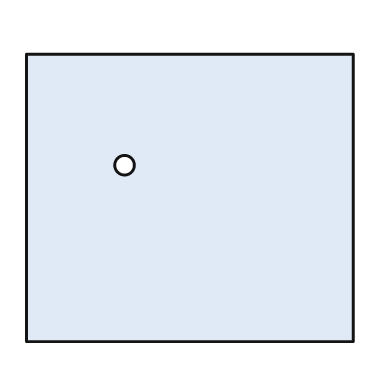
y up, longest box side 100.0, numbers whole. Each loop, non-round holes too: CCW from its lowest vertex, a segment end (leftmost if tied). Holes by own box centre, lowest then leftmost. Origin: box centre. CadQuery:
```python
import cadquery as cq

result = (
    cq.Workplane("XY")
    .moveTo(-50.0, -44.0)
    .lineTo(50.0, -44.0)
    .lineTo(50.0, 44.0)
    .lineTo(-50.0, 44.0)
    .close()
    .moveTo(-20.0, 10.0)
    .circle(3.0)
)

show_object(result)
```